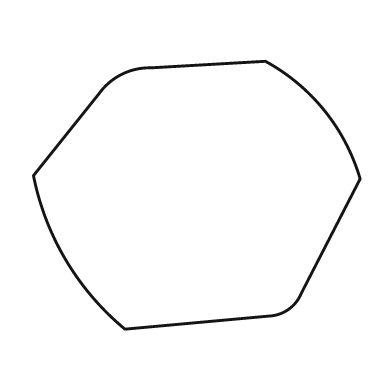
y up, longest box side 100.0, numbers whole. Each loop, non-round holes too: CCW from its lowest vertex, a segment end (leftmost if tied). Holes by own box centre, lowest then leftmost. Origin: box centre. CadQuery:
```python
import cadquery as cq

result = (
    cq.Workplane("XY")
    .moveTo(-22.0, -41.0)
    .lineTo(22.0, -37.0)
    .threePointArc((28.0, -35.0), (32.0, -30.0))
    .lineTo(50.0, 5.0)
    .threePointArc((39.0, 26.0), (21.0, 41.0))
    .lineTo(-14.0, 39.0)
    .threePointArc((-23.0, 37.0), (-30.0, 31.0))
    .lineTo(-50.0, 6.0)
    .threePointArc((-40.0, -20.0), (-22.0, -41.0))
    .close()
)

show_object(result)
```